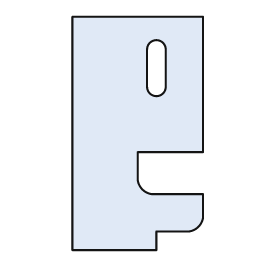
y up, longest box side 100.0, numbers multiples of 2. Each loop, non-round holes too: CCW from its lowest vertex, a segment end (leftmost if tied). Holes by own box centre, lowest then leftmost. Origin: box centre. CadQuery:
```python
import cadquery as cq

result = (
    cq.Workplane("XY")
    .moveTo(-28.0, -50.0)
    .lineTo(8.0, -50.0)
    .lineTo(8.0, -42.0)
    .lineTo(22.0, -42.0)
    .threePointArc((26.0, -40.0), (28.0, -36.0))
    .lineTo(28.0, -26.0)
    .lineTo(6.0, -26.0)
    .threePointArc((2.0, -24.0), (0.0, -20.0))
    .lineTo(0.0, -8.0)
    .lineTo(28.0, -8.0)
    .lineTo(28.0, 50.0)
    .lineTo(-28.0, 50.0)
    .close()
    .moveTo(4.0, 20.0)
    .threePointArc((8.0, 16.0), (12.0, 20.0))
    .lineTo(12.0, 36.0)
    .threePointArc((8.0, 40.0), (4.0, 36.0))
    .close()
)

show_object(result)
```